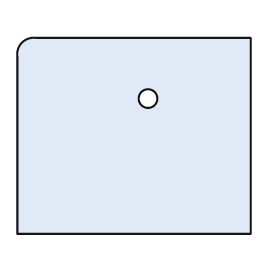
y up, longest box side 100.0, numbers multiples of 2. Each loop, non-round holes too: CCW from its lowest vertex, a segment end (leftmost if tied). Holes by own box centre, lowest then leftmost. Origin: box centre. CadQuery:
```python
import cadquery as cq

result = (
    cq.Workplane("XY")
    .moveTo(-50.0, -42.0)
    .lineTo(50.0, -42.0)
    .lineTo(50.0, 42.0)
    .lineTo(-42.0, 42.0)
    .threePointArc((-48.0, 40.0), (-50.0, 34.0))
    .close()
    .moveTo(6.0, 16.0)
    .circle(4.0)
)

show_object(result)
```